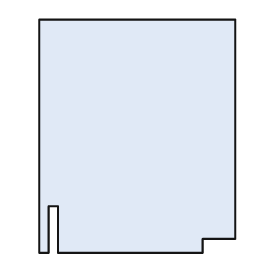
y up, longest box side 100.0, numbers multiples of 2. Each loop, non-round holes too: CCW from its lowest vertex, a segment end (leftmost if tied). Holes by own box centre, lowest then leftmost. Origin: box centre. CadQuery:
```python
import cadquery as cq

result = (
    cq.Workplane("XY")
    .moveTo(-42.0, -50.0)
    .lineTo(-38.0, -50.0)
    .lineTo(-38.0, -30.0)
    .lineTo(-34.0, -30.0)
    .lineTo(-34.0, -50.0)
    .lineTo(28.0, -50.0)
    .lineTo(28.0, -44.0)
    .lineTo(42.0, -44.0)
    .lineTo(42.0, 50.0)
    .lineTo(-42.0, 50.0)
    .close()
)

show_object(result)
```